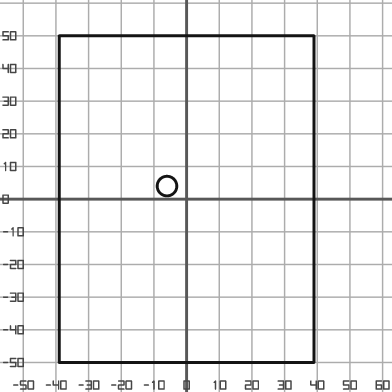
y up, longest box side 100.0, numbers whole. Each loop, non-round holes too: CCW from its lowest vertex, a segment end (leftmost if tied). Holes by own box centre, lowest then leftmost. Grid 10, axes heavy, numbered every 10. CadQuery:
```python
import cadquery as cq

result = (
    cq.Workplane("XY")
    .moveTo(-39.0, -50.0)
    .lineTo(39.0, -50.0)
    .lineTo(39.0, 50.0)
    .lineTo(-39.0, 50.0)
    .close()
    .moveTo(-6.0, 4.0)
    .circle(3.0)
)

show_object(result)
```